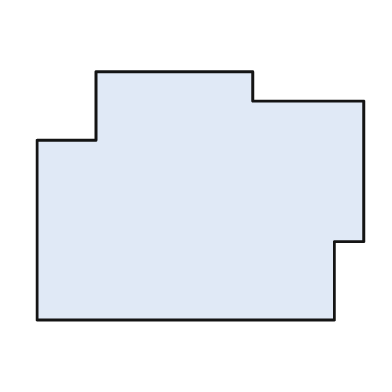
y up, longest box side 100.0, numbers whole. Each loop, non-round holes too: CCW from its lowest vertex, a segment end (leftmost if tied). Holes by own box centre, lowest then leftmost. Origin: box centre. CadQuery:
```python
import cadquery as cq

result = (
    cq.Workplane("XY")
    .moveTo(-50.0, -38.0)
    .lineTo(41.0, -38.0)
    .lineTo(41.0, -14.0)
    .lineTo(50.0, -14.0)
    .lineTo(50.0, 29.0)
    .lineTo(16.0, 29.0)
    .lineTo(16.0, 38.0)
    .lineTo(-32.0, 38.0)
    .lineTo(-32.0, 17.0)
    .lineTo(-50.0, 17.0)
    .close()
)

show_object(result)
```